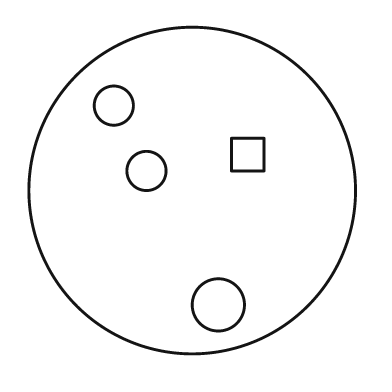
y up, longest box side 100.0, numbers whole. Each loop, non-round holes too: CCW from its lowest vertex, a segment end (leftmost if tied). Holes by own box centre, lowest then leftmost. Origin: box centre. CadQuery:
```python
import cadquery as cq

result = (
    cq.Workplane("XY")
    .moveTo(0.0, 0.0)
    .circle(50.0)
    .moveTo(8.0, -35.0)
    .circle(8.0)
    .moveTo(-14.0, 6.0)
    .circle(6.0)
    .moveTo(12.0, 6.0)
    .lineTo(22.0, 6.0)
    .lineTo(22.0, 16.0)
    .lineTo(12.0, 16.0)
    .close()
    .moveTo(-24.0, 26.0)
    .circle(6.0)
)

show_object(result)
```